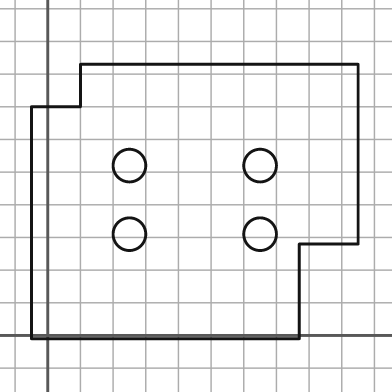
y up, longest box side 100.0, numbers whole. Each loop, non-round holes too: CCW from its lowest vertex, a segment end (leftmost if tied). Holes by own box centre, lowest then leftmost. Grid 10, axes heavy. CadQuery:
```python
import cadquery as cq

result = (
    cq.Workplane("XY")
    .moveTo(-5.0, -1.0)
    .lineTo(77.0, -1.0)
    .lineTo(77.0, 28.0)
    .lineTo(95.0, 28.0)
    .lineTo(95.0, 83.0)
    .lineTo(10.0, 83.0)
    .lineTo(10.0, 70.0)
    .lineTo(-5.0, 70.0)
    .close()
    .moveTo(25.0, 31.0)
    .circle(5.0)
    .moveTo(65.0, 31.0)
    .circle(5.0)
    .moveTo(25.0, 52.0)
    .circle(5.0)
    .moveTo(65.0, 52.0)
    .circle(5.0)
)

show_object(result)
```